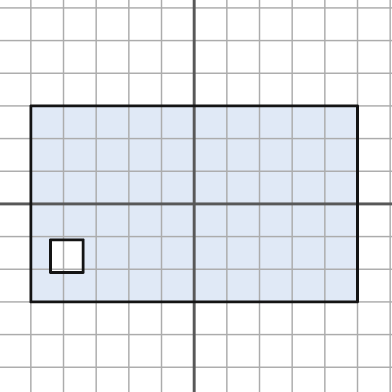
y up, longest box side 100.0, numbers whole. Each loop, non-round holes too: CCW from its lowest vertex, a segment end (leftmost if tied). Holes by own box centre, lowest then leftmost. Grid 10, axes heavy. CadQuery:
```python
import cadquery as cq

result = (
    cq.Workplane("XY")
    .moveTo(-50.0, -30.0)
    .lineTo(50.0, -30.0)
    .lineTo(50.0, 30.0)
    .lineTo(-50.0, 30.0)
    .close()
    .moveTo(-44.0, -21.0)
    .lineTo(-34.0, -21.0)
    .lineTo(-34.0, -11.0)
    .lineTo(-44.0, -11.0)
    .close()
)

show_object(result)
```